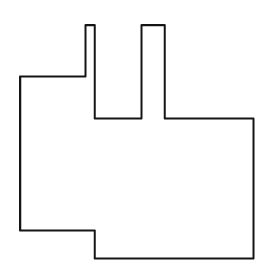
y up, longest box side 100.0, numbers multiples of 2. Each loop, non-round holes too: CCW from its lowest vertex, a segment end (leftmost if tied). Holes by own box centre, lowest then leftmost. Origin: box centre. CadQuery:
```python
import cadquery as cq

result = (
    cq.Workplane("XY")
    .moveTo(-18.0, -50.0)
    .lineTo(50.0, -50.0)
    .lineTo(50.0, 10.0)
    .lineTo(12.0, 10.0)
    .lineTo(12.0, 50.0)
    .lineTo(2.0, 50.0)
    .lineTo(2.0, 10.0)
    .lineTo(-18.0, 10.0)
    .lineTo(-18.0, 50.0)
    .lineTo(-22.0, 50.0)
    .lineTo(-22.0, 28.0)
    .lineTo(-50.0, 28.0)
    .lineTo(-50.0, -38.0)
    .lineTo(-18.0, -38.0)
    .close()
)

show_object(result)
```